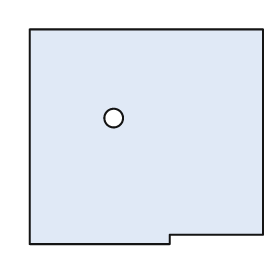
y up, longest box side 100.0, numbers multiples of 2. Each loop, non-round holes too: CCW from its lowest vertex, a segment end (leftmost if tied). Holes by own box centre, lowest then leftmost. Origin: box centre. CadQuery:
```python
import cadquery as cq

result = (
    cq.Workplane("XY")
    .moveTo(-50.0, -46.0)
    .lineTo(10.0, -46.0)
    .lineTo(10.0, -42.0)
    .lineTo(50.0, -42.0)
    .lineTo(50.0, 46.0)
    .lineTo(-50.0, 46.0)
    .close()
    .moveTo(-14.0, 8.0)
    .circle(4.0)
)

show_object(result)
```